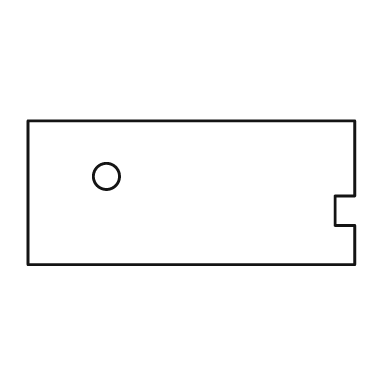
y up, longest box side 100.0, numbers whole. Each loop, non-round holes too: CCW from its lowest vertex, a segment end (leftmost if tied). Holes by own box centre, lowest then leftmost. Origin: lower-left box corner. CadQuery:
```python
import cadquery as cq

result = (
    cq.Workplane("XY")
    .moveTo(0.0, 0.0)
    .lineTo(100.0, 0.0)
    .lineTo(100.0, 12.0)
    .lineTo(94.0, 12.0)
    .lineTo(94.0, 21.0)
    .lineTo(100.0, 21.0)
    .lineTo(100.0, 44.0)
    .lineTo(0.0, 44.0)
    .close()
    .moveTo(24.0, 27.0)
    .circle(4.0)
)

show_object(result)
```